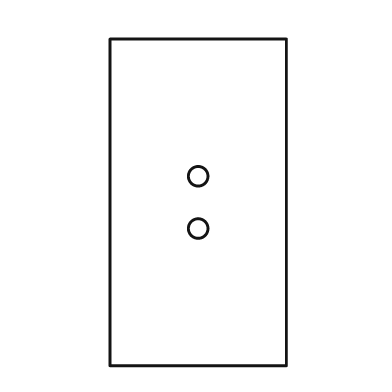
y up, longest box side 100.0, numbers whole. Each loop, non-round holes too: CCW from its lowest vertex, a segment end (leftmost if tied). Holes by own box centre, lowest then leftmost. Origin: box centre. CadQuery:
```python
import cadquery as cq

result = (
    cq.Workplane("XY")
    .moveTo(-27.0, -50.0)
    .lineTo(27.0, -50.0)
    .lineTo(27.0, 50.0)
    .lineTo(-27.0, 50.0)
    .close()
    .moveTo(0.0, -8.0)
    .circle(3.0)
    .moveTo(0.0, 8.0)
    .circle(3.0)
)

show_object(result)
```